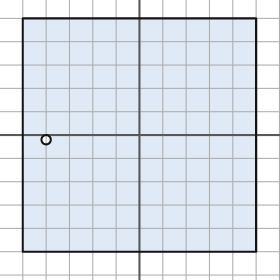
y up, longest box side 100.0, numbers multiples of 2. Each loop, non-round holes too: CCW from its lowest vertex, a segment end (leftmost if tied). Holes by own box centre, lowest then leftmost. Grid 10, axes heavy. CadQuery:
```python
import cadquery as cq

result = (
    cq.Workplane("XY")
    .moveTo(-50.0, -50.0)
    .lineTo(50.0, -50.0)
    .lineTo(50.0, 50.0)
    .lineTo(-50.0, 50.0)
    .close()
    .moveTo(-40.0, -2.0)
    .circle(2.0)
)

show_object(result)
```